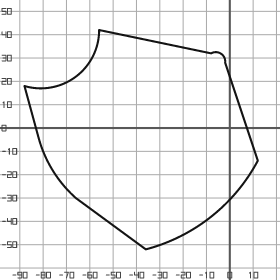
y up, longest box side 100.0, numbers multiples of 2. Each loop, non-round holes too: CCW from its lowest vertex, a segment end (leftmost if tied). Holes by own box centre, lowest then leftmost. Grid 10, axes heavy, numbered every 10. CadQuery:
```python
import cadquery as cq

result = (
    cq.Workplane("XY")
    .moveTo(-36.0, -52.0)
    .threePointArc((-8.0, -38.0), (12.0, -14.0))
    .lineTo(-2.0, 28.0)
    .threePointArc((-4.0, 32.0), (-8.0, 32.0))
    .lineTo(-56.0, 42.0)
    .threePointArc((-66.0, 22.0), (-88.0, 18.0))
    .lineTo(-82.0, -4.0)
    .threePointArc((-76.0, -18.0), (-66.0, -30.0))
    .close()
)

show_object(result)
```